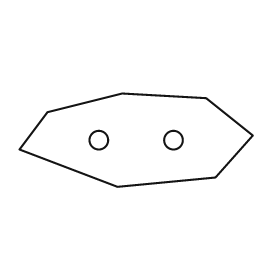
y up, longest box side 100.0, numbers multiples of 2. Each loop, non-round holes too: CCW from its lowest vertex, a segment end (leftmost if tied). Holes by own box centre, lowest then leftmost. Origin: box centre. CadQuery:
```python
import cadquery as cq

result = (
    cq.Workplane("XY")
    .moveTo(-8.0, -20.0)
    .lineTo(34.0, -16.0)
    .lineTo(50.0, 2.0)
    .lineTo(30.0, 18.0)
    .lineTo(-6.0, 20.0)
    .lineTo(-38.0, 12.0)
    .lineTo(-50.0, -4.0)
    .close()
    .moveTo(-16.0, 0.0)
    .circle(4.0)
    .moveTo(16.0, 0.0)
    .circle(4.0)
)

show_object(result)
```